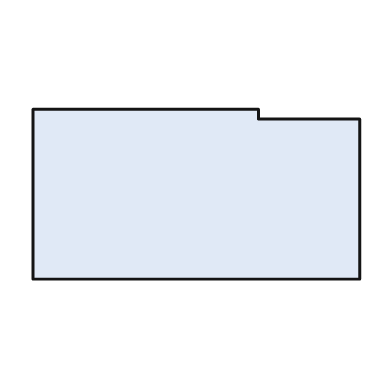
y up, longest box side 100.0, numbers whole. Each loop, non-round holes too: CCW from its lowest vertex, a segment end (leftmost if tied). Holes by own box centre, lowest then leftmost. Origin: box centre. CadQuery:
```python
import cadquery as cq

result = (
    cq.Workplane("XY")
    .moveTo(-50.0, -26.0)
    .lineTo(50.0, -26.0)
    .lineTo(50.0, 23.0)
    .lineTo(19.0, 23.0)
    .lineTo(19.0, 26.0)
    .lineTo(-50.0, 26.0)
    .close()
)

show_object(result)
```